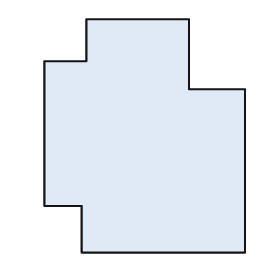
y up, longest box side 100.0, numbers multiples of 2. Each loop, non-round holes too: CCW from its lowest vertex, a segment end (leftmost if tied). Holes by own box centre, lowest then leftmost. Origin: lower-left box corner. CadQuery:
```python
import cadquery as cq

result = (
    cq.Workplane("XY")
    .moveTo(16.0, 0.0)
    .lineTo(86.0, 0.0)
    .lineTo(86.0, 70.0)
    .lineTo(62.0, 70.0)
    .lineTo(62.0, 100.0)
    .lineTo(18.0, 100.0)
    .lineTo(18.0, 82.0)
    .lineTo(0.0, 82.0)
    .lineTo(0.0, 20.0)
    .lineTo(16.0, 20.0)
    .close()
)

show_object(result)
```